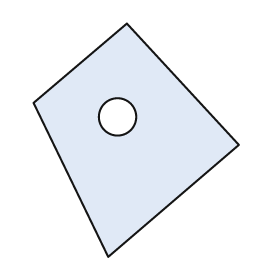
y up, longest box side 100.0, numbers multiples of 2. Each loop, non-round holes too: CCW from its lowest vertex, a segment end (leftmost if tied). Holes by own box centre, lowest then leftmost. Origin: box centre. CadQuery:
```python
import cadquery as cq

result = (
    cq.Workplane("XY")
    .moveTo(-12.0, -50.0)
    .lineTo(44.0, -2.0)
    .lineTo(-4.0, 50.0)
    .lineTo(-44.0, 16.0)
    .close()
    .moveTo(-8.0, 10.0)
    .circle(8.0)
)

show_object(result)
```